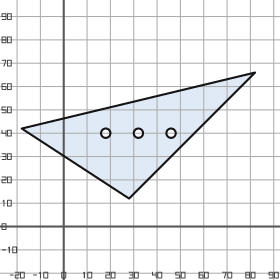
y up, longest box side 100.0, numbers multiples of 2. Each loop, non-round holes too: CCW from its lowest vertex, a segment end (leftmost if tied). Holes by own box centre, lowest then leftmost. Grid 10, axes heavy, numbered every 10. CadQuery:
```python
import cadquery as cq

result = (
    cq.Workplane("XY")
    .moveTo(28.0, 12.0)
    .lineTo(82.0, 66.0)
    .lineTo(-18.0, 42.0)
    .close()
    .moveTo(18.0, 40.0)
    .circle(2.0)
    .moveTo(32.0, 40.0)
    .circle(2.0)
    .moveTo(46.0, 40.0)
    .circle(2.0)
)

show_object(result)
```